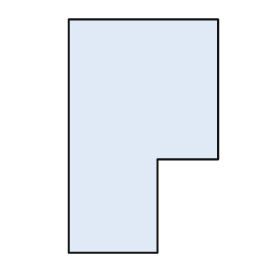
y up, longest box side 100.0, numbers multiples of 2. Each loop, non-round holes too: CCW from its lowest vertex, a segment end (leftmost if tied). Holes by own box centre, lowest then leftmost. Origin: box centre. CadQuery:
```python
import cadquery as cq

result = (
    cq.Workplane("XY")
    .moveTo(-32.0, -50.0)
    .lineTo(6.0, -50.0)
    .lineTo(6.0, -10.0)
    .lineTo(32.0, -10.0)
    .lineTo(32.0, 50.0)
    .lineTo(-32.0, 50.0)
    .close()
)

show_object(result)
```